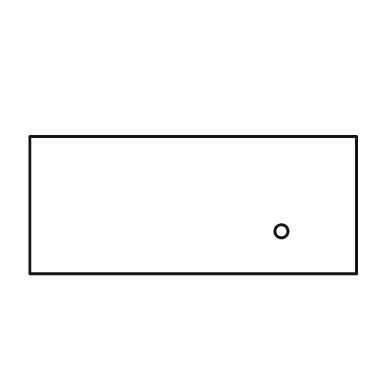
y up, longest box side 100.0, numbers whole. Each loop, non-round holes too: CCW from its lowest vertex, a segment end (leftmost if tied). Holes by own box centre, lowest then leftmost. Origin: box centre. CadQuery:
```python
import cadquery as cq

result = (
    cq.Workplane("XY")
    .moveTo(-50.0, -21.0)
    .lineTo(50.0, -21.0)
    .lineTo(50.0, 21.0)
    .lineTo(-50.0, 21.0)
    .close()
    .moveTo(27.0, -8.0)
    .circle(2.0)
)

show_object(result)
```